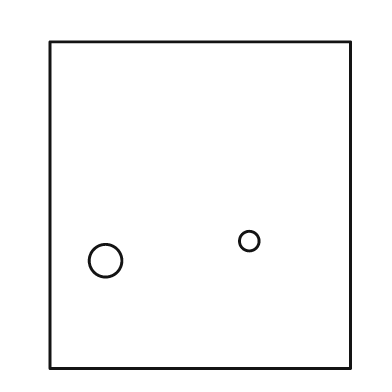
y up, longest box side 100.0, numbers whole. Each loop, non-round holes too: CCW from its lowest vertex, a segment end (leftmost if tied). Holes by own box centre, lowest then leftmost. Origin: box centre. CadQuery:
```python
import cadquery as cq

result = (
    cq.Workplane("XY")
    .moveTo(-46.0, -50.0)
    .lineTo(46.0, -50.0)
    .lineTo(46.0, 50.0)
    .lineTo(-46.0, 50.0)
    .close()
    .moveTo(-29.0, -17.0)
    .circle(5.0)
    .moveTo(15.0, -11.0)
    .circle(3.0)
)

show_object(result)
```